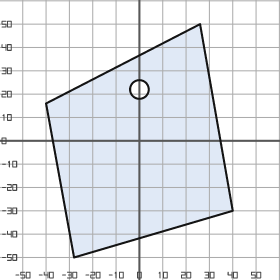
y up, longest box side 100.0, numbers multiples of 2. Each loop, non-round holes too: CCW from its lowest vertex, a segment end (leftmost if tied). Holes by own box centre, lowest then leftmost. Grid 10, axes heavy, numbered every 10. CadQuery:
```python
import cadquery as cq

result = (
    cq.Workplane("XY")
    .moveTo(-28.0, -50.0)
    .lineTo(40.0, -30.0)
    .lineTo(26.0, 50.0)
    .lineTo(-40.0, 16.0)
    .close()
    .moveTo(0.0, 22.0)
    .circle(4.0)
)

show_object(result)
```